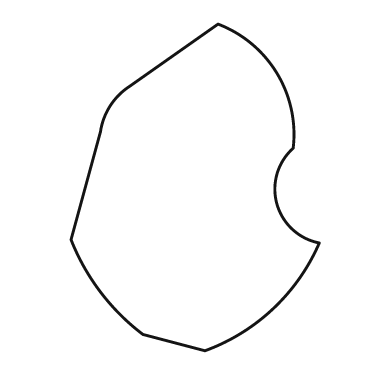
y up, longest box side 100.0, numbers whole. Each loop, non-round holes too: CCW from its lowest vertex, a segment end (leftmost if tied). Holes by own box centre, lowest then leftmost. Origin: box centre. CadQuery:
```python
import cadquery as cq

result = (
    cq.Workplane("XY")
    .moveTo(3.0, -50.0)
    .threePointArc((24.0, -37.0), (38.0, -17.0))
    .threePointArc((25.0, -5.0), (30.0, 12.0))
    .threePointArc((25.0, 35.0), (7.0, 50.0))
    .lineTo(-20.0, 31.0)
    .threePointArc((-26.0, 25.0), (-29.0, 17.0))
    .lineTo(-38.0, -16.0)
    .threePointArc((-29.0, -32.0), (-16.0, -45.0))
    .close()
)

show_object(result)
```